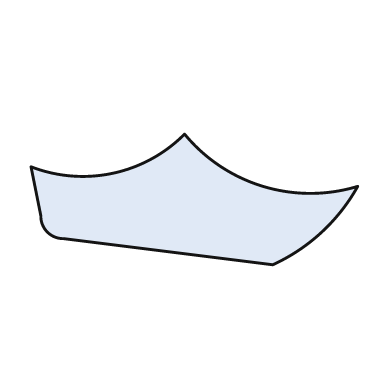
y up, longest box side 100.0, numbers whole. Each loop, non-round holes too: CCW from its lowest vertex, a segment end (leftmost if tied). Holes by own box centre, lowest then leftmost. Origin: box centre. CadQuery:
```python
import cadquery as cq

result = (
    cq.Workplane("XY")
    .moveTo(24.0, -20.0)
    .threePointArc((39.0, -10.0), (50.0, 4.0))
    .threePointArc((21.0, 4.0), (-3.0, 20.0))
    .threePointArc((-25.0, 8.0), (-50.0, 10.0))
    .lineTo(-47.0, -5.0)
    .threePointArc((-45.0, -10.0), (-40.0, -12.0))
    .close()
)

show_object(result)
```